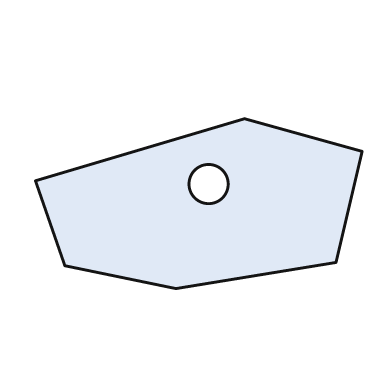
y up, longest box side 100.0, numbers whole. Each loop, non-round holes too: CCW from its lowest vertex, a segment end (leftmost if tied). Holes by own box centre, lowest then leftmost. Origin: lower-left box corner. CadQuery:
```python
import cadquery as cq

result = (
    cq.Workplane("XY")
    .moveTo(43.0, 0.0)
    .lineTo(92.0, 8.0)
    .lineTo(100.0, 42.0)
    .lineTo(64.0, 52.0)
    .lineTo(0.0, 33.0)
    .lineTo(9.0, 7.0)
    .close()
    .moveTo(53.0, 32.0)
    .circle(6.0)
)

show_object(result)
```